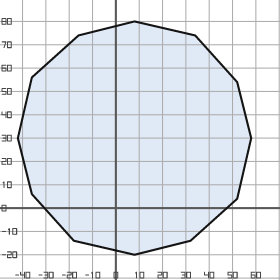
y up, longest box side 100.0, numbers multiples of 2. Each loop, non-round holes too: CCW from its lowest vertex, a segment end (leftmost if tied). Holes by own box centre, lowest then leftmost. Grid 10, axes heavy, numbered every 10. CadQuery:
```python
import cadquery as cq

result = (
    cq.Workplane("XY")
    .moveTo(8.0, -20.0)
    .lineTo(32.0, -14.0)
    .lineTo(52.0, 4.0)
    .lineTo(58.0, 30.0)
    .lineTo(52.0, 54.0)
    .lineTo(34.0, 74.0)
    .lineTo(8.0, 80.0)
    .lineTo(-16.0, 74.0)
    .lineTo(-36.0, 56.0)
    .lineTo(-42.0, 30.0)
    .lineTo(-36.0, 6.0)
    .lineTo(-18.0, -14.0)
    .close()
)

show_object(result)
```